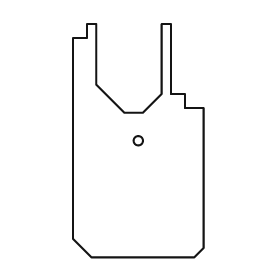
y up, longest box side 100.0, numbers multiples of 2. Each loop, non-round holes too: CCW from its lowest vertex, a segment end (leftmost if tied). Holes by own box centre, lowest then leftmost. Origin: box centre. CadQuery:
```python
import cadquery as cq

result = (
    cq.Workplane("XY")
    .moveTo(-20.0, -50.0)
    .lineTo(24.0, -50.0)
    .lineTo(28.0, -46.0)
    .lineTo(28.0, 14.0)
    .lineTo(20.0, 14.0)
    .lineTo(20.0, 20.0)
    .lineTo(14.0, 20.0)
    .lineTo(14.0, 50.0)
    .lineTo(10.0, 50.0)
    .lineTo(10.0, 20.0)
    .lineTo(2.0, 12.0)
    .lineTo(-6.0, 12.0)
    .lineTo(-18.0, 24.0)
    .lineTo(-18.0, 50.0)
    .lineTo(-22.0, 50.0)
    .lineTo(-22.0, 44.0)
    .lineTo(-28.0, 44.0)
    .lineTo(-28.0, -42.0)
    .close()
    .moveTo(0.0, 0.0)
    .circle(2.0)
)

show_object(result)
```